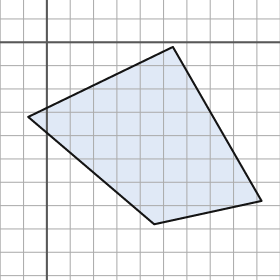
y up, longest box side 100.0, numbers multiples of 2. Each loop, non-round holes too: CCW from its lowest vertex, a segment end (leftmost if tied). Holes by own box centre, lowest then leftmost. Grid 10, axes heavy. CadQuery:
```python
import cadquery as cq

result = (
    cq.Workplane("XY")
    .moveTo(46.0, -78.0)
    .lineTo(92.0, -68.0)
    .lineTo(54.0, -2.0)
    .lineTo(-8.0, -32.0)
    .close()
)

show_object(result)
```